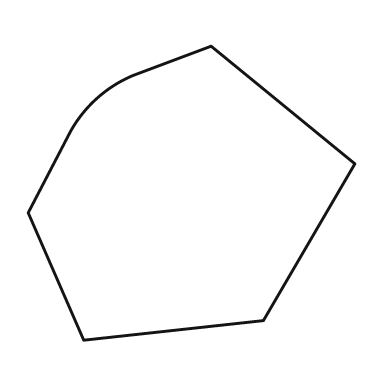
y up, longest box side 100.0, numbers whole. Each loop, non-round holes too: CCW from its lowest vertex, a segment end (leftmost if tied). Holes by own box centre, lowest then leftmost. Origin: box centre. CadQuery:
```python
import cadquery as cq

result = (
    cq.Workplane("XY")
    .moveTo(-33.0, -45.0)
    .lineTo(22.0, -39.0)
    .lineTo(50.0, 9.0)
    .lineTo(6.0, 45.0)
    .lineTo(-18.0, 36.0)
    .threePointArc((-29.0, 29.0), (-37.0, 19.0))
    .lineTo(-50.0, -6.0)
    .close()
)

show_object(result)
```